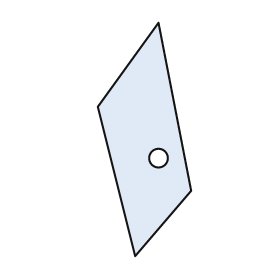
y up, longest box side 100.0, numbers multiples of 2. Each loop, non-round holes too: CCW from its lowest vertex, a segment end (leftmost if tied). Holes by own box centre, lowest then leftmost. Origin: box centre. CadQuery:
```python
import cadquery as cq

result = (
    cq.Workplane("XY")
    .moveTo(-4.0, -50.0)
    .lineTo(20.0, -22.0)
    .lineTo(6.0, 50.0)
    .lineTo(-20.0, 14.0)
    .close()
    .moveTo(6.0, -8.0)
    .circle(4.0)
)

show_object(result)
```